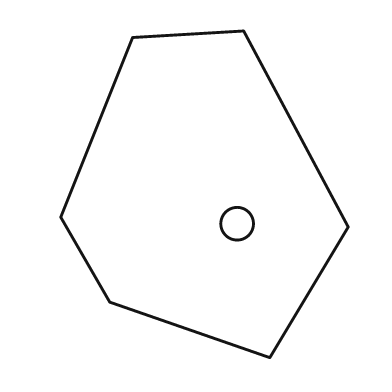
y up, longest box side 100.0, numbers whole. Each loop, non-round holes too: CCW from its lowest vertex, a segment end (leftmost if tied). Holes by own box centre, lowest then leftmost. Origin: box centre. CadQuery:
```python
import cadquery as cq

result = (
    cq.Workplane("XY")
    .moveTo(20.0, -50.0)
    .lineTo(44.0, -10.0)
    .lineTo(12.0, 50.0)
    .lineTo(-22.0, 48.0)
    .lineTo(-44.0, -7.0)
    .lineTo(-29.0, -33.0)
    .close()
    .moveTo(10.0, -9.0)
    .circle(5.0)
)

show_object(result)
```